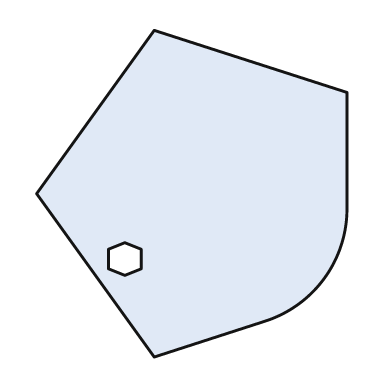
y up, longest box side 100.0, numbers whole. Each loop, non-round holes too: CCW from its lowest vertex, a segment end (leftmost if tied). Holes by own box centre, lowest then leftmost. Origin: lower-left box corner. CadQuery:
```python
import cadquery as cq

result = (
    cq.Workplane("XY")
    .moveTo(36.0, 0.0)
    .lineTo(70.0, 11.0)
    .threePointArc((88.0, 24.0), (95.0, 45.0))
    .lineTo(95.0, 81.0)
    .lineTo(36.0, 100.0)
    .lineTo(0.0, 50.0)
    .close()
    .moveTo(27.0, 25.0)
    .lineTo(32.0, 27.0)
    .lineTo(32.0, 33.0)
    .lineTo(27.0, 35.0)
    .lineTo(22.0, 33.0)
    .lineTo(22.0, 27.0)
    .close()
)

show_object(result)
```